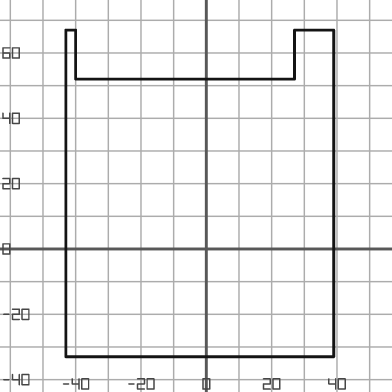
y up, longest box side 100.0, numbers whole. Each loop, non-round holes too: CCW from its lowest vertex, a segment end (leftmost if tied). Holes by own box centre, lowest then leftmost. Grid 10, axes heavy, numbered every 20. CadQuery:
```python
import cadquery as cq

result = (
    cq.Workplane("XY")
    .moveTo(-43.0, -33.0)
    .lineTo(39.0, -33.0)
    .lineTo(39.0, 67.0)
    .lineTo(27.0, 67.0)
    .lineTo(27.0, 52.0)
    .lineTo(-40.0, 52.0)
    .lineTo(-40.0, 67.0)
    .lineTo(-43.0, 67.0)
    .close()
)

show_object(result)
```